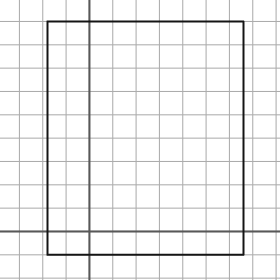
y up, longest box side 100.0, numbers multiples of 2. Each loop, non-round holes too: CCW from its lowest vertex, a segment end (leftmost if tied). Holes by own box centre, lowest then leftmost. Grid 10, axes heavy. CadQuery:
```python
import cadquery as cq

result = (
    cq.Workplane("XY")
    .moveTo(-18.0, -10.0)
    .lineTo(66.0, -10.0)
    .lineTo(66.0, 90.0)
    .lineTo(-18.0, 90.0)
    .close()
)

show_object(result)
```